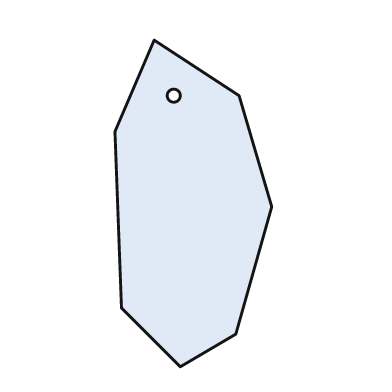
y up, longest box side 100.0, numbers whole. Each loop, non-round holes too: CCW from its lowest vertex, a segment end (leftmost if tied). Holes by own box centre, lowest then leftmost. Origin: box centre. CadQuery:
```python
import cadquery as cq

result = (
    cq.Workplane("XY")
    .moveTo(-4.0, -50.0)
    .lineTo(13.0, -40.0)
    .lineTo(24.0, -1.0)
    .lineTo(14.0, 33.0)
    .lineTo(-12.0, 50.0)
    .lineTo(-24.0, 22.0)
    .lineTo(-22.0, -32.0)
    .close()
    .moveTo(-6.0, 33.0)
    .circle(2.0)
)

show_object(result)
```